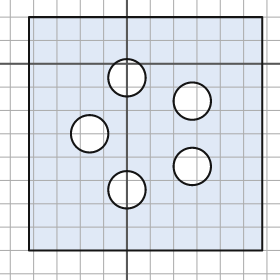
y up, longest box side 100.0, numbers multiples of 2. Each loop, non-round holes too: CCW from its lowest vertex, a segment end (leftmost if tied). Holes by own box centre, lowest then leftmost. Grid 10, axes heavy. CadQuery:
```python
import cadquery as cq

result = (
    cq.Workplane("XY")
    .moveTo(-42.0, -80.0)
    .lineTo(58.0, -80.0)
    .lineTo(58.0, 20.0)
    .lineTo(-42.0, 20.0)
    .close()
    .moveTo(0.0, -54.0)
    .circle(8.0)
    .moveTo(28.0, -44.0)
    .circle(8.0)
    .moveTo(-16.0, -30.0)
    .circle(8.0)
    .moveTo(28.0, -16.0)
    .circle(8.0)
    .moveTo(0.0, -6.0)
    .circle(8.0)
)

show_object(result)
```